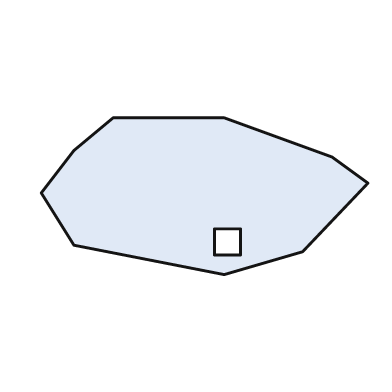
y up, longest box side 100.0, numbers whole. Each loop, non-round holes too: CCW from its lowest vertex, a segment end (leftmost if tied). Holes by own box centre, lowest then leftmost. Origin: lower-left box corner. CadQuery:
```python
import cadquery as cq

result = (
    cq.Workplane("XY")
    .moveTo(56.0, 0.0)
    .lineTo(80.0, 7.0)
    .lineTo(100.0, 28.0)
    .lineTo(89.0, 36.0)
    .lineTo(56.0, 48.0)
    .lineTo(22.0, 48.0)
    .lineTo(10.0, 38.0)
    .lineTo(0.0, 25.0)
    .lineTo(10.0, 9.0)
    .close()
    .moveTo(53.0, 6.0)
    .lineTo(61.0, 6.0)
    .lineTo(61.0, 14.0)
    .lineTo(53.0, 14.0)
    .close()
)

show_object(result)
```